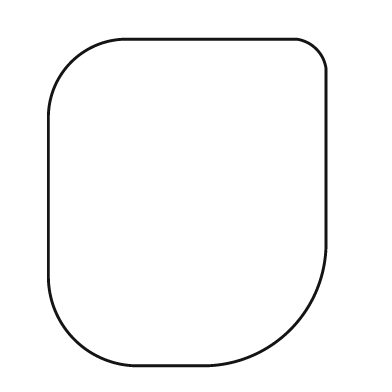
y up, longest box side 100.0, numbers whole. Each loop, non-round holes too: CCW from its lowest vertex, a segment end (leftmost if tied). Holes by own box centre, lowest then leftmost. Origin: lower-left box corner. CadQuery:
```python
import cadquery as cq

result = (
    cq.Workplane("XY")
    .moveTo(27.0, 0.0)
    .lineTo(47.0, 0.0)
    .threePointArc((74.0, 11.0), (85.0, 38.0))
    .lineTo(85.0, 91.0)
    .threePointArc((82.0, 97.0), (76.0, 100.0))
    .lineTo(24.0, 100.0)
    .threePointArc((7.0, 93.0), (0.0, 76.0))
    .lineTo(0.0, 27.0)
    .threePointArc((8.0, 8.0), (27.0, 0.0))
    .close()
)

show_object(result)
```